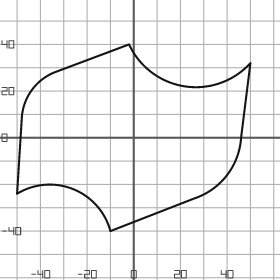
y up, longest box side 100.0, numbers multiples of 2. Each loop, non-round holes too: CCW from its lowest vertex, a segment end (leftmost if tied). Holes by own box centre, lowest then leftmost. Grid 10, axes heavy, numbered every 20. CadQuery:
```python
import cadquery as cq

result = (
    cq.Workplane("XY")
    .moveTo(-10.0, -40.0)
    .lineTo(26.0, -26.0)
    .threePointArc((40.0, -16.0), (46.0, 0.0))
    .lineTo(50.0, 32.0)
    .threePointArc((22.0, 22.0), (-2.0, 40.0))
    .lineTo(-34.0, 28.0)
    .threePointArc((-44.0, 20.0), (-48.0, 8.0))
    .lineTo(-50.0, -24.0)
    .threePointArc((-26.0, -22.0), (-10.0, -40.0))
    .close()
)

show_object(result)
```